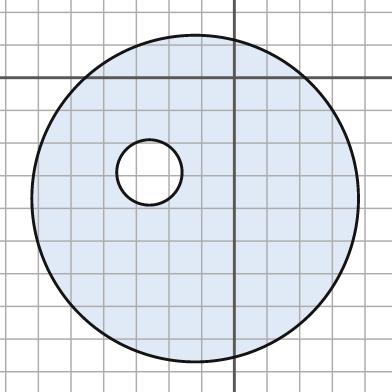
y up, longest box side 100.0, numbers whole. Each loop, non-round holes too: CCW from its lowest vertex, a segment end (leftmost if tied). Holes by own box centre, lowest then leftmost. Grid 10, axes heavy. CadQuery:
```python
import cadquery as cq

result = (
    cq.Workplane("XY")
    .moveTo(-12.0, -37.0)
    .circle(50.0)
    .moveTo(-26.0, -29.0)
    .circle(10.0)
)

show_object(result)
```